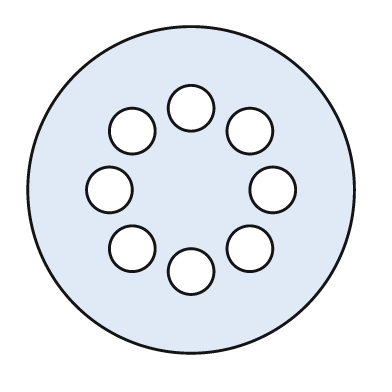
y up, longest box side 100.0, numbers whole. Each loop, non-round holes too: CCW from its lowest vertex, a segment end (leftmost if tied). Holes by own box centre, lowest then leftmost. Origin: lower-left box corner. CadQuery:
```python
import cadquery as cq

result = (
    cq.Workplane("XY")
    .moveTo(50.0, 50.0)
    .circle(50.0)
    .moveTo(50.0, 25.0)
    .circle(7.0)
    .moveTo(32.0, 32.0)
    .circle(7.0)
    .moveTo(68.0, 32.0)
    .circle(7.0)
    .moveTo(25.0, 50.0)
    .circle(7.0)
    .moveTo(75.0, 50.0)
    .circle(7.0)
    .moveTo(32.0, 68.0)
    .circle(7.0)
    .moveTo(68.0, 68.0)
    .circle(7.0)
    .moveTo(50.0, 75.0)
    .circle(7.0)
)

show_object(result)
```